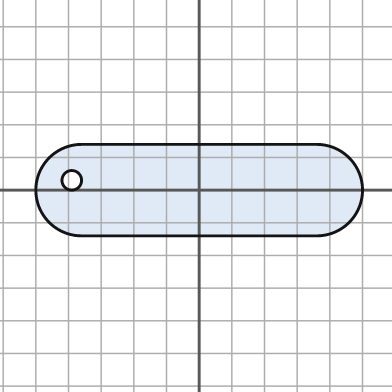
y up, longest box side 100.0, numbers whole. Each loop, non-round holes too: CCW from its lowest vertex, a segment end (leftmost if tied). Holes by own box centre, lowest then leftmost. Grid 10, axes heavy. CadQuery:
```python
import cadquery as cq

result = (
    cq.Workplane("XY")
    .moveTo(-36.0, -14.0)
    .lineTo(36.0, -14.0)
    .threePointArc((50.0, 0.0), (36.0, 14.0))
    .lineTo(-36.0, 14.0)
    .threePointArc((-50.0, 0.0), (-36.0, -14.0))
    .close()
    .moveTo(-39.0, 3.0)
    .circle(3.0)
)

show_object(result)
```